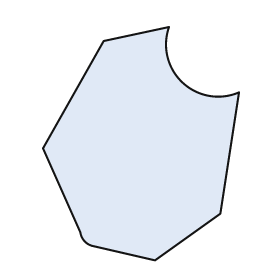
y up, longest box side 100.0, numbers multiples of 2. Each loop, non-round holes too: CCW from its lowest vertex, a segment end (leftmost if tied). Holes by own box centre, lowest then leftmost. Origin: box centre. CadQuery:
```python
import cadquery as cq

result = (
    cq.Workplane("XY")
    .moveTo(6.0, -50.0)
    .lineTo(34.0, -30.0)
    .lineTo(42.0, 22.0)
    .threePointArc((18.0, 26.0), (12.0, 50.0))
    .lineTo(-16.0, 44.0)
    .lineTo(-42.0, -2.0)
    .lineTo(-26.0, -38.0)
    .threePointArc((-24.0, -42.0), (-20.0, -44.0))
    .close()
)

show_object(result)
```